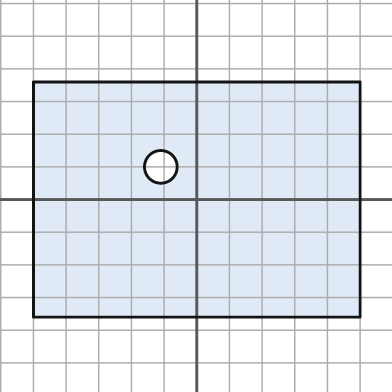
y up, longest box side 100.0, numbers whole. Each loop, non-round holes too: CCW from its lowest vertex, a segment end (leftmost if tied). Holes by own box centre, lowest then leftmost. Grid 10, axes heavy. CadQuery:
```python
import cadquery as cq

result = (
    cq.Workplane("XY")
    .moveTo(-50.0, -36.0)
    .lineTo(50.0, -36.0)
    .lineTo(50.0, 36.0)
    .lineTo(-50.0, 36.0)
    .close()
    .moveTo(-11.0, 10.0)
    .circle(5.0)
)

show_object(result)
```